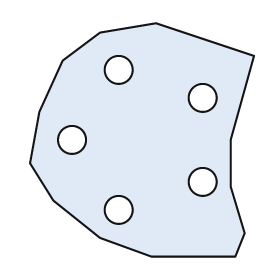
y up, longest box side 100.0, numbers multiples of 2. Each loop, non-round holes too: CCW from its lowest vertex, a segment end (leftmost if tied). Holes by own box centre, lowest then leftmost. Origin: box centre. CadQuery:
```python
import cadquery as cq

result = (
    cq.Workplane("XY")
    .moveTo(4.0, -50.0)
    .lineTo(40.0, -50.0)
    .lineTo(44.0, -40.0)
    .lineTo(38.0, -20.0)
    .lineTo(38.0, 0.0)
    .lineTo(48.0, 36.0)
    .lineTo(6.0, 50.0)
    .lineTo(-18.0, 46.0)
    .lineTo(-34.0, 34.0)
    .lineTo(-44.0, 12.0)
    .lineTo(-48.0, -10.0)
    .lineTo(-38.0, -26.0)
    .lineTo(-18.0, -42.0)
    .close()
    .moveTo(-10.0, -30.0)
    .circle(6.0)
    .moveTo(26.0, -18.0)
    .circle(6.0)
    .moveTo(-30.0, 0.0)
    .circle(6.0)
    .moveTo(26.0, 18.0)
    .circle(6.0)
    .moveTo(-10.0, 30.0)
    .circle(6.0)
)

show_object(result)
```